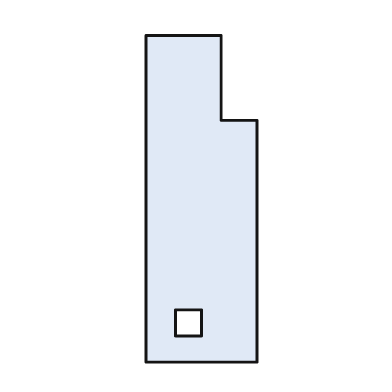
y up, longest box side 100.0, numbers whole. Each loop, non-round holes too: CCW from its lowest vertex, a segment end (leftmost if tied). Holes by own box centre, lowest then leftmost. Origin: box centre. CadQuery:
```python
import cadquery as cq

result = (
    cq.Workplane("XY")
    .moveTo(-17.0, -50.0)
    .lineTo(17.0, -50.0)
    .lineTo(17.0, 24.0)
    .lineTo(6.0, 24.0)
    .lineTo(6.0, 50.0)
    .lineTo(-17.0, 50.0)
    .close()
    .moveTo(-8.0, -42.0)
    .lineTo(0.0, -42.0)
    .lineTo(0.0, -34.0)
    .lineTo(-8.0, -34.0)
    .close()
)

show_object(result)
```